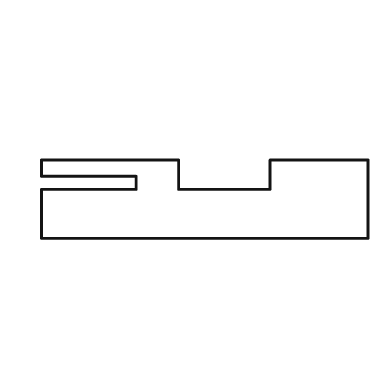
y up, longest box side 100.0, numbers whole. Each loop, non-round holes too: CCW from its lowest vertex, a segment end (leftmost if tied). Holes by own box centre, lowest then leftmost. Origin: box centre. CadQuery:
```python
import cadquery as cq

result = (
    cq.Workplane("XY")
    .moveTo(-50.0, -12.0)
    .lineTo(50.0, -12.0)
    .lineTo(50.0, 12.0)
    .lineTo(20.0, 12.0)
    .lineTo(20.0, 3.0)
    .lineTo(-8.0, 3.0)
    .lineTo(-8.0, 12.0)
    .lineTo(-50.0, 12.0)
    .lineTo(-50.0, 7.0)
    .lineTo(-21.0, 7.0)
    .lineTo(-21.0, 3.0)
    .lineTo(-50.0, 3.0)
    .close()
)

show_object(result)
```